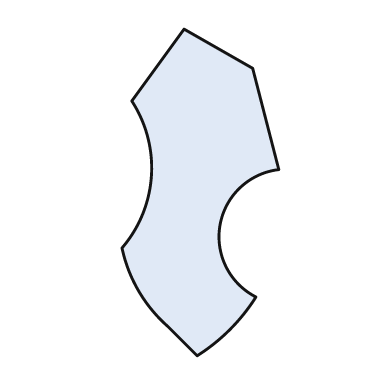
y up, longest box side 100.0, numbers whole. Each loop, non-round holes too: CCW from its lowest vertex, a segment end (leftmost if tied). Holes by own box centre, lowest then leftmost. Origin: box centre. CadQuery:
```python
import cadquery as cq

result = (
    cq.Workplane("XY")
    .moveTo(-1.0, -50.0)
    .threePointArc((9.0, -42.0), (17.0, -32.0))
    .threePointArc((6.0, -10.0), (24.0, 7.0))
    .lineTo(16.0, 38.0)
    .lineTo(-5.0, 50.0)
    .lineTo(-21.0, 28.0)
    .threePointArc((-15.0, 5.0), (-24.0, -17.0))
    .threePointArc((-19.0, -30.0), (-10.0, -41.0))
    .close()
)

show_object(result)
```